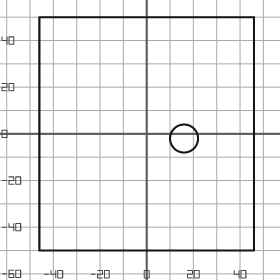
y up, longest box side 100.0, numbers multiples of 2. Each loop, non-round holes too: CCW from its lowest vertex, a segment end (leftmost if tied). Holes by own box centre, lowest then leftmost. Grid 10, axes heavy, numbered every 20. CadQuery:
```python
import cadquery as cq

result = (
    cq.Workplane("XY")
    .moveTo(-46.0, -50.0)
    .lineTo(46.0, -50.0)
    .lineTo(46.0, 50.0)
    .lineTo(-46.0, 50.0)
    .close()
    .moveTo(16.0, -2.0)
    .circle(6.0)
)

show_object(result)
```